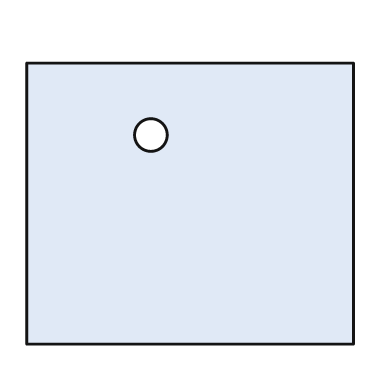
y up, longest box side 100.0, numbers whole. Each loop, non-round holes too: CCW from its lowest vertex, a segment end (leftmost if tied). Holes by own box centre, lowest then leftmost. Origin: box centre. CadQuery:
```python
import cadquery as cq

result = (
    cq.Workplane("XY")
    .moveTo(-50.0, -43.0)
    .lineTo(50.0, -43.0)
    .lineTo(50.0, 43.0)
    .lineTo(-50.0, 43.0)
    .close()
    .moveTo(-12.0, 21.0)
    .circle(5.0)
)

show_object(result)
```